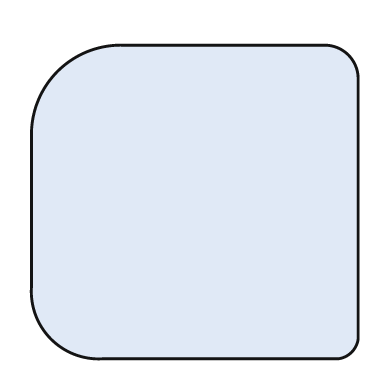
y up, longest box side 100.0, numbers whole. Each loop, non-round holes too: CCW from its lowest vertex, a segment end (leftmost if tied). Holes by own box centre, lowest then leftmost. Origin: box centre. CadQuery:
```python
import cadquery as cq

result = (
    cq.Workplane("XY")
    .moveTo(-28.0, -48.0)
    .lineTo(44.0, -48.0)
    .threePointArc((48.0, -46.0), (50.0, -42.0))
    .lineTo(50.0, 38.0)
    .threePointArc((47.0, 45.0), (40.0, 48.0))
    .lineTo(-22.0, 48.0)
    .threePointArc((-42.0, 40.0), (-50.0, 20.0))
    .lineTo(-50.0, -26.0)
    .threePointArc((-44.0, -42.0), (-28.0, -48.0))
    .close()
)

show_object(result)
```